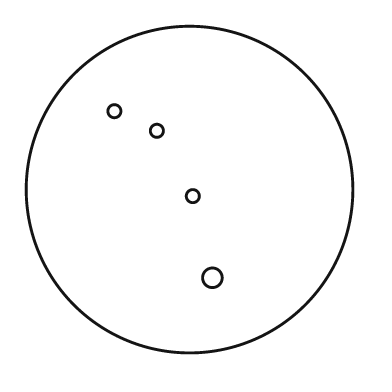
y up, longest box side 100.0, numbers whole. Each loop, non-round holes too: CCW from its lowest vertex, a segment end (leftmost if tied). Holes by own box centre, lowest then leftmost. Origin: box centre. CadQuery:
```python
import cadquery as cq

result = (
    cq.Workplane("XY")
    .moveTo(0.0, 0.0)
    .circle(50.0)
    .moveTo(7.0, -27.0)
    .circle(3.0)
    .moveTo(1.0, -2.0)
    .circle(2.0)
    .moveTo(-10.0, 18.0)
    .circle(2.0)
    .moveTo(-23.0, 24.0)
    .circle(2.0)
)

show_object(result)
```